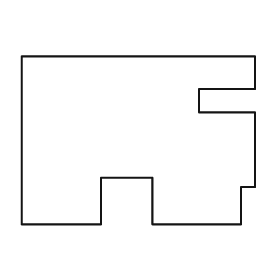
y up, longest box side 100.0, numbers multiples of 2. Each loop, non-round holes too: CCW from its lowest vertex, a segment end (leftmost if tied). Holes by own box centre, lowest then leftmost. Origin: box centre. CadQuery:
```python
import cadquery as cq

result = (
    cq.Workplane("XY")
    .moveTo(-50.0, -36.0)
    .lineTo(-16.0, -36.0)
    .lineTo(-16.0, -16.0)
    .lineTo(6.0, -16.0)
    .lineTo(6.0, -36.0)
    .lineTo(44.0, -36.0)
    .lineTo(44.0, -20.0)
    .lineTo(50.0, -20.0)
    .lineTo(50.0, 12.0)
    .lineTo(26.0, 12.0)
    .lineTo(26.0, 22.0)
    .lineTo(50.0, 22.0)
    .lineTo(50.0, 36.0)
    .lineTo(-50.0, 36.0)
    .close()
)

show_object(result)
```